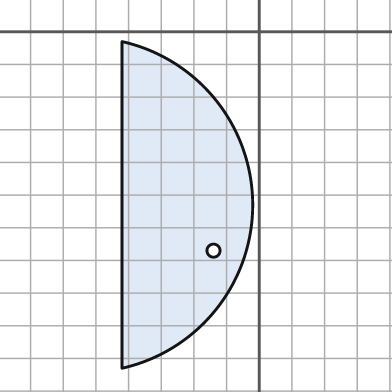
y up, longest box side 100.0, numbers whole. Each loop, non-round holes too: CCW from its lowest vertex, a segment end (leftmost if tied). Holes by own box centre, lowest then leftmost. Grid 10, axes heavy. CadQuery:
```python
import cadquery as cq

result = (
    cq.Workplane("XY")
    .moveTo(-42.0, -103.0)
    .threePointArc((-2.0, -53.0), (-42.0, -3.0))
    .close()
    .moveTo(-14.0, -67.0)
    .circle(2.0)
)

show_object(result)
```